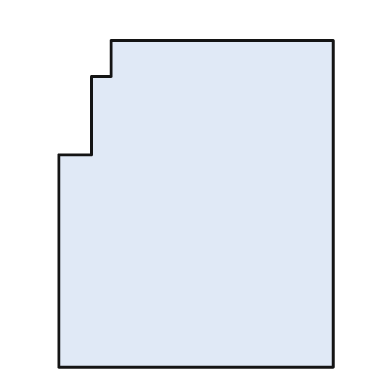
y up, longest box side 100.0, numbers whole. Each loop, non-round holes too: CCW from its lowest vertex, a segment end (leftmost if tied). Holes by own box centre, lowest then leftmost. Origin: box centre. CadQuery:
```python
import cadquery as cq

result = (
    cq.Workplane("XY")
    .moveTo(-42.0, -50.0)
    .lineTo(42.0, -50.0)
    .lineTo(42.0, 50.0)
    .lineTo(-26.0, 50.0)
    .lineTo(-26.0, 39.0)
    .lineTo(-32.0, 39.0)
    .lineTo(-32.0, 15.0)
    .lineTo(-42.0, 15.0)
    .close()
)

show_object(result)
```